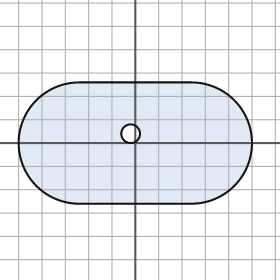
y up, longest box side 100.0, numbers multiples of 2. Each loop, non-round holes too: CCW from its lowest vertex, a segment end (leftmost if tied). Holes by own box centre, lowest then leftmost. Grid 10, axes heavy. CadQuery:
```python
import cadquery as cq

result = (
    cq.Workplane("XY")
    .moveTo(-24.0, -26.0)
    .lineTo(24.0, -26.0)
    .threePointArc((50.0, 0.0), (24.0, 26.0))
    .lineTo(-24.0, 26.0)
    .threePointArc((-50.0, 0.0), (-24.0, -26.0))
    .close()
    .moveTo(-2.0, 4.0)
    .circle(4.0)
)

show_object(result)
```